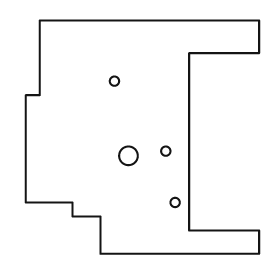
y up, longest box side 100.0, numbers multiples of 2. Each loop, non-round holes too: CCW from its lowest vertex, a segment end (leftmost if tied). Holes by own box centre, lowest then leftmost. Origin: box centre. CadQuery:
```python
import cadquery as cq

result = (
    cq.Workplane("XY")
    .moveTo(-18.0, -50.0)
    .lineTo(50.0, -50.0)
    .lineTo(50.0, -40.0)
    .lineTo(20.0, -40.0)
    .lineTo(20.0, 36.0)
    .lineTo(50.0, 36.0)
    .lineTo(50.0, 50.0)
    .lineTo(-44.0, 50.0)
    .lineTo(-44.0, 18.0)
    .lineTo(-50.0, 18.0)
    .lineTo(-50.0, -28.0)
    .lineTo(-30.0, -28.0)
    .lineTo(-30.0, -34.0)
    .lineTo(-18.0, -34.0)
    .close()
    .moveTo(14.0, -28.0)
    .circle(2.0)
    .moveTo(-6.0, -8.0)
    .circle(4.0)
    .moveTo(10.0, -6.0)
    .circle(2.0)
    .moveTo(-12.0, 24.0)
    .circle(2.0)
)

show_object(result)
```